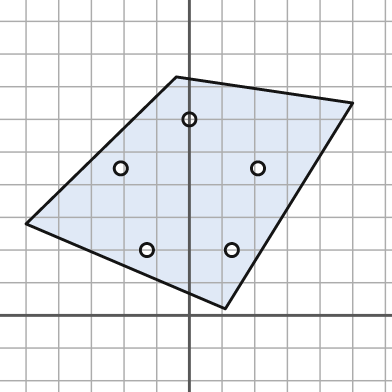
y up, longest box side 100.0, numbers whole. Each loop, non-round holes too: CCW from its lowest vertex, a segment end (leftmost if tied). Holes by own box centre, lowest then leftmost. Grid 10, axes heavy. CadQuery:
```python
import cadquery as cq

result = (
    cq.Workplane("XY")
    .moveTo(11.0, 2.0)
    .lineTo(50.0, 65.0)
    .lineTo(-4.0, 73.0)
    .lineTo(-50.0, 28.0)
    .close()
    .moveTo(-13.0, 20.0)
    .circle(2.0)
    .moveTo(13.0, 20.0)
    .circle(2.0)
    .moveTo(-21.0, 45.0)
    .circle(2.0)
    .moveTo(21.0, 45.0)
    .circle(2.0)
    .moveTo(0.0, 60.0)
    .circle(2.0)
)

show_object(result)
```